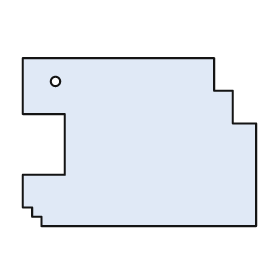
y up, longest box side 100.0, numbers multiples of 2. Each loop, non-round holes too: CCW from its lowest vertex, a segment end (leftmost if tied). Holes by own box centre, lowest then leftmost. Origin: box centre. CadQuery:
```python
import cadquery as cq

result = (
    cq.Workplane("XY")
    .moveTo(-42.0, -36.0)
    .lineTo(50.0, -36.0)
    .lineTo(50.0, 8.0)
    .lineTo(40.0, 8.0)
    .lineTo(40.0, 22.0)
    .lineTo(32.0, 22.0)
    .lineTo(32.0, 36.0)
    .lineTo(-50.0, 36.0)
    .lineTo(-50.0, 12.0)
    .lineTo(-32.0, 12.0)
    .lineTo(-32.0, -14.0)
    .lineTo(-50.0, -14.0)
    .lineTo(-50.0, -28.0)
    .lineTo(-46.0, -28.0)
    .lineTo(-46.0, -32.0)
    .lineTo(-42.0, -32.0)
    .close()
    .moveTo(-36.0, 26.0)
    .circle(2.0)
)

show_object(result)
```